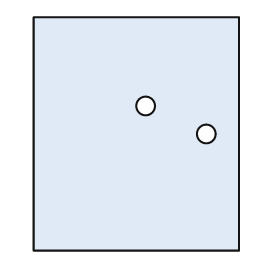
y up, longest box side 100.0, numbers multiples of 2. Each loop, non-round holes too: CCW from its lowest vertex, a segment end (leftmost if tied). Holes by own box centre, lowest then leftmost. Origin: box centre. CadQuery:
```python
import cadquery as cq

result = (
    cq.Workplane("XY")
    .moveTo(-44.0, -50.0)
    .lineTo(44.0, -50.0)
    .lineTo(44.0, 50.0)
    .lineTo(-44.0, 50.0)
    .close()
    .moveTo(30.0, 0.0)
    .circle(4.0)
    .moveTo(4.0, 12.0)
    .circle(4.0)
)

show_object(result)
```